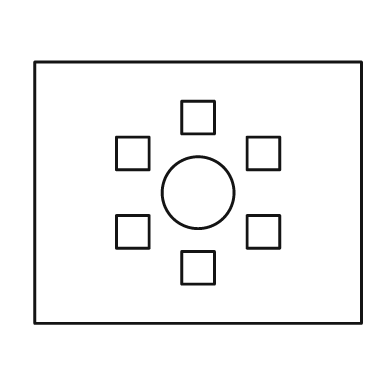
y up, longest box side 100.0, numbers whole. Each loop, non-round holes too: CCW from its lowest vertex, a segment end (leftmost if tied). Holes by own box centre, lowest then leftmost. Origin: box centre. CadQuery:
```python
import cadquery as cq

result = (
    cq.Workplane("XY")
    .moveTo(-50.0, -40.0)
    .lineTo(50.0, -40.0)
    .lineTo(50.0, 40.0)
    .lineTo(-50.0, 40.0)
    .close()
    .moveTo(-5.0, -28.0)
    .lineTo(5.0, -28.0)
    .lineTo(5.0, -18.0)
    .lineTo(-5.0, -18.0)
    .close()
    .moveTo(-25.0, -17.0)
    .lineTo(-15.0, -17.0)
    .lineTo(-15.0, -7.0)
    .lineTo(-25.0, -7.0)
    .close()
    .moveTo(15.0, -17.0)
    .lineTo(25.0, -17.0)
    .lineTo(25.0, -7.0)
    .lineTo(15.0, -7.0)
    .close()
    .moveTo(0.0, 0.0)
    .circle(11.0)
    .moveTo(-25.0, 7.0)
    .lineTo(-15.0, 7.0)
    .lineTo(-15.0, 17.0)
    .lineTo(-25.0, 17.0)
    .close()
    .moveTo(15.0, 7.0)
    .lineTo(25.0, 7.0)
    .lineTo(25.0, 17.0)
    .lineTo(15.0, 17.0)
    .close()
    .moveTo(-5.0, 18.0)
    .lineTo(5.0, 18.0)
    .lineTo(5.0, 28.0)
    .lineTo(-5.0, 28.0)
    .close()
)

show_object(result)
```